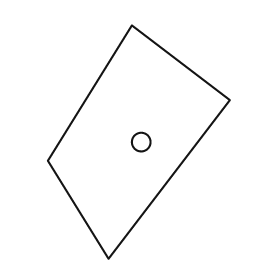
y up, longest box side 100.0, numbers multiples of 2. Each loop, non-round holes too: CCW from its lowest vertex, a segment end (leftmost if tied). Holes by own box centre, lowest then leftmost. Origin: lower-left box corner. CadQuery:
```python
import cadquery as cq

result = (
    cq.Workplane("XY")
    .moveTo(26.0, 0.0)
    .lineTo(78.0, 68.0)
    .lineTo(36.0, 100.0)
    .lineTo(0.0, 42.0)
    .close()
    .moveTo(40.0, 50.0)
    .circle(4.0)
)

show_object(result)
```